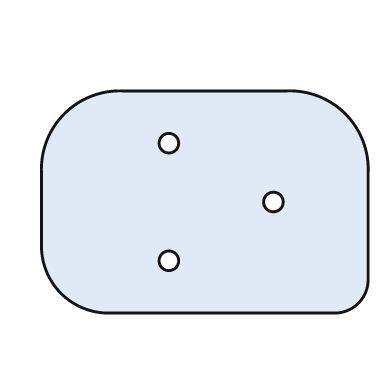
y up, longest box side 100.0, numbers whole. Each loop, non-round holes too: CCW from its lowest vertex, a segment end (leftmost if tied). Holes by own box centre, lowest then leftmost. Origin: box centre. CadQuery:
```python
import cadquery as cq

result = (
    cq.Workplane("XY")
    .moveTo(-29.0, -34.0)
    .lineTo(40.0, -34.0)
    .threePointArc((47.0, -31.0), (50.0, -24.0))
    .lineTo(50.0, 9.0)
    .threePointArc((43.0, 27.0), (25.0, 34.0))
    .lineTo(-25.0, 34.0)
    .threePointArc((-43.0, 27.0), (-50.0, 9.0))
    .lineTo(-50.0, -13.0)
    .threePointArc((-44.0, -28.0), (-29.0, -34.0))
    .close()
    .moveTo(-11.0, -18.0)
    .circle(3.0)
    .moveTo(21.0, 0.0)
    .circle(3.0)
    .moveTo(-11.0, 18.0)
    .circle(3.0)
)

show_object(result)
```